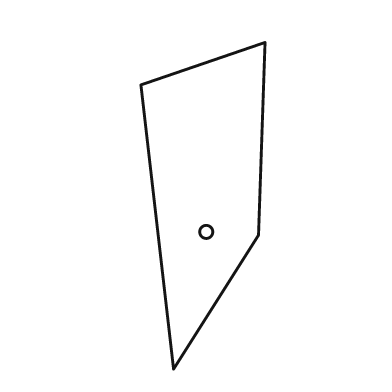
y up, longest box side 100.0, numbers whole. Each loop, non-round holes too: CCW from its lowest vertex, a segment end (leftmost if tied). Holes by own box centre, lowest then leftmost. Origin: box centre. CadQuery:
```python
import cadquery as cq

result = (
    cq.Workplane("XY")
    .moveTo(-9.0, -50.0)
    .lineTo(17.0, -9.0)
    .lineTo(19.0, 50.0)
    .lineTo(-19.0, 37.0)
    .close()
    .moveTo(1.0, -8.0)
    .circle(2.0)
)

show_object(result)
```